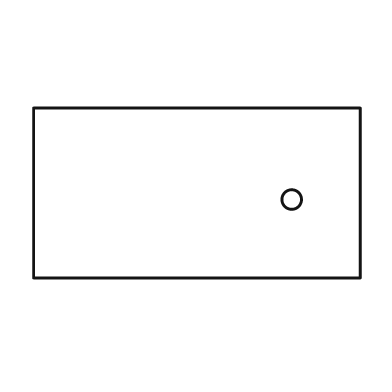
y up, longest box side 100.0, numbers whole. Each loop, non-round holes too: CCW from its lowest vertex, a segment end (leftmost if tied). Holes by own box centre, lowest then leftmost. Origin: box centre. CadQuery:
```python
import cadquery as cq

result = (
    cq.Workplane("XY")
    .moveTo(-50.0, -26.0)
    .lineTo(50.0, -26.0)
    .lineTo(50.0, 26.0)
    .lineTo(-50.0, 26.0)
    .close()
    .moveTo(29.0, -2.0)
    .circle(3.0)
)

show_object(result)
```